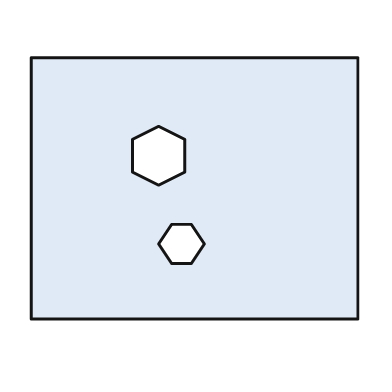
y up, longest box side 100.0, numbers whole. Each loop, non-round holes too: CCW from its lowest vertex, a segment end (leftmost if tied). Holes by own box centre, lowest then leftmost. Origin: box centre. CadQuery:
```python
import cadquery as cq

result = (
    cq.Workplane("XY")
    .moveTo(-50.0, -40.0)
    .lineTo(50.0, -40.0)
    .lineTo(50.0, 40.0)
    .lineTo(-50.0, 40.0)
    .close()
    .moveTo(-7.0, -23.0)
    .lineTo(-1.0, -23.0)
    .lineTo(3.0, -17.0)
    .lineTo(-1.0, -11.0)
    .lineTo(-7.0, -11.0)
    .lineTo(-11.0, -17.0)
    .close()
    .moveTo(-11.0, 1.0)
    .lineTo(-3.0, 5.0)
    .lineTo(-3.0, 15.0)
    .lineTo(-11.0, 19.0)
    .lineTo(-19.0, 15.0)
    .lineTo(-19.0, 5.0)
    .close()
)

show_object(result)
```